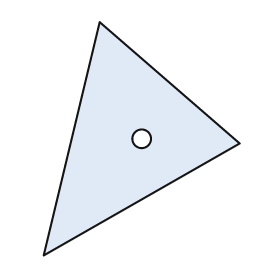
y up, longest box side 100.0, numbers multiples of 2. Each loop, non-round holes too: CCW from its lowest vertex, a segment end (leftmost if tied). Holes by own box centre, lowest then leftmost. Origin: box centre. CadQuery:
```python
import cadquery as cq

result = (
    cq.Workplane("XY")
    .moveTo(-42.0, -50.0)
    .lineTo(42.0, -2.0)
    .lineTo(-18.0, 50.0)
    .close()
    .moveTo(0.0, 0.0)
    .circle(4.0)
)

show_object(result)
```